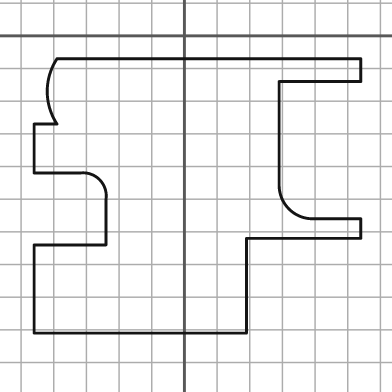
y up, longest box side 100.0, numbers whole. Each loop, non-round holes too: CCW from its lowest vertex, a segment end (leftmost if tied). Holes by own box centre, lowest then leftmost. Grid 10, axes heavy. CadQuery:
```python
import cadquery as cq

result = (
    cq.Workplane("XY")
    .moveTo(-46.0, -91.0)
    .lineTo(19.0, -91.0)
    .lineTo(19.0, -62.0)
    .lineTo(54.0, -62.0)
    .lineTo(54.0, -56.0)
    .lineTo(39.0, -56.0)
    .threePointArc((32.0, -53.0), (29.0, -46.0))
    .lineTo(29.0, -14.0)
    .lineTo(54.0, -14.0)
    .lineTo(54.0, -7.0)
    .lineTo(-39.0, -7.0)
    .threePointArc((-42.0, -17.0), (-39.0, -27.0))
    .lineTo(-46.0, -27.0)
    .lineTo(-46.0, -42.0)
    .lineTo(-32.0, -42.0)
    .threePointArc((-26.0, -44.0), (-24.0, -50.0))
    .lineTo(-24.0, -64.0)
    .lineTo(-46.0, -64.0)
    .close()
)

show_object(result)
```